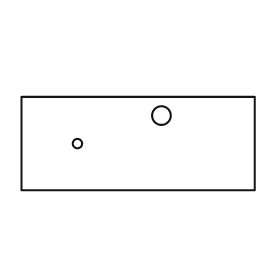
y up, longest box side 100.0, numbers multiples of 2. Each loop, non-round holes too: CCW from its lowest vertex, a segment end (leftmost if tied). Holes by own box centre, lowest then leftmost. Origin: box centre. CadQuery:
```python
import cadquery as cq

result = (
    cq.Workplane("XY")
    .moveTo(-50.0, -20.0)
    .lineTo(50.0, -20.0)
    .lineTo(50.0, 20.0)
    .lineTo(-50.0, 20.0)
    .close()
    .moveTo(-26.0, 0.0)
    .circle(2.0)
    .moveTo(10.0, 12.0)
    .circle(4.0)
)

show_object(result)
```